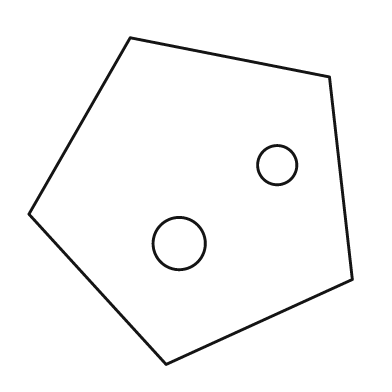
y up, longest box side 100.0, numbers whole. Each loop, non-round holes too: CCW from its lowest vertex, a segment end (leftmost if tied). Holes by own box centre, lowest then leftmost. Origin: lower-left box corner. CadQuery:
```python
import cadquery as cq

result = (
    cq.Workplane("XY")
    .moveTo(42.0, 0.0)
    .lineTo(99.0, 26.0)
    .lineTo(92.0, 88.0)
    .lineTo(31.0, 100.0)
    .lineTo(0.0, 46.0)
    .close()
    .moveTo(46.0, 37.0)
    .circle(8.0)
    .moveTo(76.0, 61.0)
    .circle(6.0)
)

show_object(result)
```